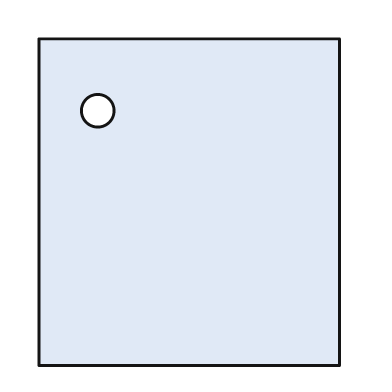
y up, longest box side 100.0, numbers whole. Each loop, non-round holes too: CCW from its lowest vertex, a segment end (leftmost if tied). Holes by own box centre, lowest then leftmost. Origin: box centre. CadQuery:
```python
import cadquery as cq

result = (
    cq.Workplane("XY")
    .moveTo(-46.0, -50.0)
    .lineTo(46.0, -50.0)
    .lineTo(46.0, 50.0)
    .lineTo(-46.0, 50.0)
    .close()
    .moveTo(-28.0, 28.0)
    .circle(5.0)
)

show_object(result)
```